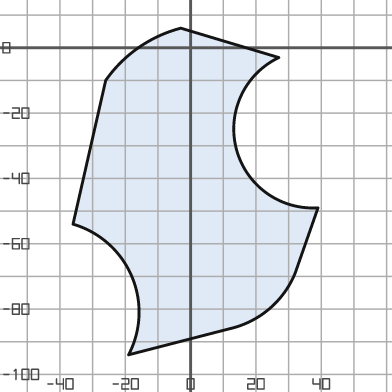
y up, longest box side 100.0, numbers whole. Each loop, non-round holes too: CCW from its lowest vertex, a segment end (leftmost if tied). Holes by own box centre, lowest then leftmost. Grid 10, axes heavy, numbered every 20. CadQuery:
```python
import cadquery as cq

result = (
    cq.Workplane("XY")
    .moveTo(-19.0, -94.0)
    .lineTo(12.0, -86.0)
    .threePointArc((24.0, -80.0), (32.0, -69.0))
    .lineTo(39.0, -49.0)
    .threePointArc((14.0, -31.0), (27.0, -3.0))
    .lineTo(-3.0, 6.0)
    .threePointArc((-16.0, 0.0), (-26.0, -10.0))
    .lineTo(-36.0, -54.0)
    .threePointArc((-18.0, -70.0), (-19.0, -94.0))
    .close()
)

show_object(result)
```